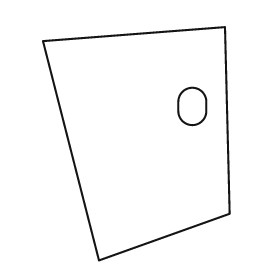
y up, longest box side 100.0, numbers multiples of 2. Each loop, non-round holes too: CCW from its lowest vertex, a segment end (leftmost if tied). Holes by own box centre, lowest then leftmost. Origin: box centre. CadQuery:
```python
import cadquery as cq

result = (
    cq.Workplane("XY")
    .moveTo(-16.0, -50.0)
    .lineTo(40.0, -30.0)
    .lineTo(38.0, 50.0)
    .lineTo(-40.0, 44.0)
    .close()
    .moveTo(18.0, 14.0)
    .threePointArc((24.0, 8.0), (30.0, 14.0))
    .lineTo(30.0, 18.0)
    .threePointArc((24.0, 24.0), (18.0, 18.0))
    .close()
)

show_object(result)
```